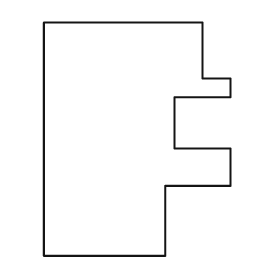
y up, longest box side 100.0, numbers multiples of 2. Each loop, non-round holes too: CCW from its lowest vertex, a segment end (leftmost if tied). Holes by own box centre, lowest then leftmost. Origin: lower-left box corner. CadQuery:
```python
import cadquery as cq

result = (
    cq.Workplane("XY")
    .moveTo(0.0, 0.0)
    .lineTo(52.0, 0.0)
    .lineTo(52.0, 30.0)
    .lineTo(80.0, 30.0)
    .lineTo(80.0, 46.0)
    .lineTo(56.0, 46.0)
    .lineTo(56.0, 68.0)
    .lineTo(80.0, 68.0)
    .lineTo(80.0, 76.0)
    .lineTo(68.0, 76.0)
    .lineTo(68.0, 100.0)
    .lineTo(0.0, 100.0)
    .close()
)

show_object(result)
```